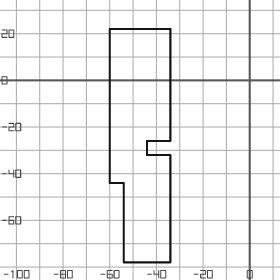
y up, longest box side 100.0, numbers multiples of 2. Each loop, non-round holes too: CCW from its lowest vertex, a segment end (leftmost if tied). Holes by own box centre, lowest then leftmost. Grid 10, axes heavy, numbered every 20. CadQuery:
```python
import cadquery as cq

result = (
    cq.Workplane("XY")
    .moveTo(-54.0, -78.0)
    .lineTo(-34.0, -78.0)
    .lineTo(-34.0, -32.0)
    .lineTo(-44.0, -32.0)
    .lineTo(-44.0, -26.0)
    .lineTo(-34.0, -26.0)
    .lineTo(-34.0, 22.0)
    .lineTo(-60.0, 22.0)
    .lineTo(-60.0, -44.0)
    .lineTo(-54.0, -44.0)
    .close()
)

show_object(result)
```